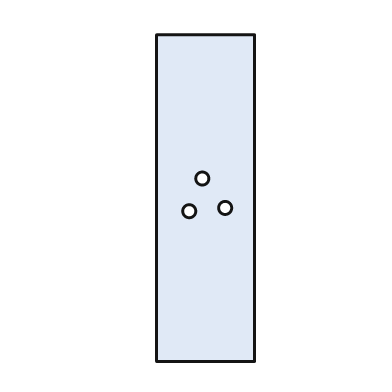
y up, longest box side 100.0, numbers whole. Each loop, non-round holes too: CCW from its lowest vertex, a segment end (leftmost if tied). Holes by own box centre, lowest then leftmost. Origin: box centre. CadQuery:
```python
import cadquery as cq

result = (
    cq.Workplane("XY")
    .moveTo(-15.0, -50.0)
    .lineTo(15.0, -50.0)
    .lineTo(15.0, 50.0)
    .lineTo(-15.0, 50.0)
    .close()
    .moveTo(-5.0, -4.0)
    .circle(2.0)
    .moveTo(6.0, -3.0)
    .circle(2.0)
    .moveTo(-1.0, 6.0)
    .circle(2.0)
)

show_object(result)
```